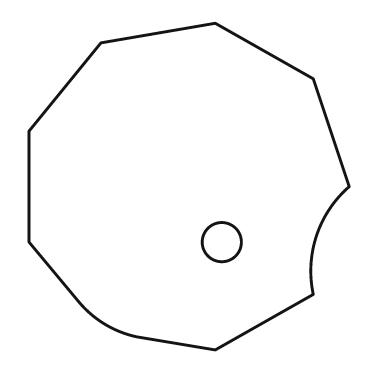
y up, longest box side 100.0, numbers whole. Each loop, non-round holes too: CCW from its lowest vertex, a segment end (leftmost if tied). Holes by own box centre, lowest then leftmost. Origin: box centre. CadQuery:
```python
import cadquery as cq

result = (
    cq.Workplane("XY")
    .moveTo(8.0, -50.0)
    .lineTo(38.0, -33.0)
    .threePointArc((39.0, -15.0), (49.0, 0.0))
    .lineTo(38.0, 33.0)
    .lineTo(8.0, 50.0)
    .lineTo(-27.0, 44.0)
    .lineTo(-49.0, 17.0)
    .lineTo(-49.0, -17.0)
    .lineTo(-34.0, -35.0)
    .threePointArc((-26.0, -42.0), (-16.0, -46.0))
    .close()
    .moveTo(10.0, -17.0)
    .circle(6.0)
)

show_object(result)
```